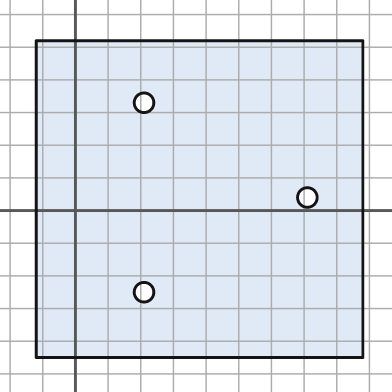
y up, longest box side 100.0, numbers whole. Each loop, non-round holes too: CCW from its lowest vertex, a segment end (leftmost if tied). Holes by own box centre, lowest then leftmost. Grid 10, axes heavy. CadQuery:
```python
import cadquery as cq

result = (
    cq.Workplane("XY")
    .moveTo(-12.0, -45.0)
    .lineTo(88.0, -45.0)
    .lineTo(88.0, 52.0)
    .lineTo(-12.0, 52.0)
    .close()
    .moveTo(21.0, -25.0)
    .circle(3.0)
    .moveTo(71.0, 4.0)
    .circle(3.0)
    .moveTo(21.0, 33.0)
    .circle(3.0)
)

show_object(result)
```